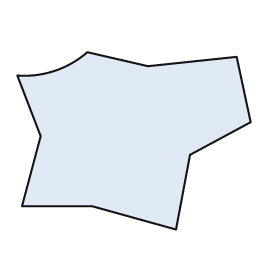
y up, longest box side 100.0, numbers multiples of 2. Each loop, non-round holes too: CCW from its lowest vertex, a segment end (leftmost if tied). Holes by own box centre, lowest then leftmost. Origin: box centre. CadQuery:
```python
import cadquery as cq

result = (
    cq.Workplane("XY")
    .moveTo(18.0, -38.0)
    .lineTo(24.0, -6.0)
    .lineTo(50.0, 8.0)
    .lineTo(44.0, 36.0)
    .lineTo(6.0, 32.0)
    .lineTo(-20.0, 38.0)
    .threePointArc((-34.0, 30.0), (-50.0, 28.0))
    .lineTo(-40.0, 2.0)
    .lineTo(-48.0, -28.0)
    .lineTo(-18.0, -28.0)
    .close()
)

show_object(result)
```